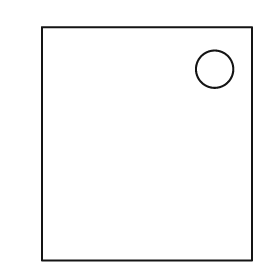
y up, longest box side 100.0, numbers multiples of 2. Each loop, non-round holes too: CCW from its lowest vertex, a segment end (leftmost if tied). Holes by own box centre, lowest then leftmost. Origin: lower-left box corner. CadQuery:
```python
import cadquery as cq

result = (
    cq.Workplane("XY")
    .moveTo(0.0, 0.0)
    .lineTo(90.0, 0.0)
    .lineTo(90.0, 100.0)
    .lineTo(0.0, 100.0)
    .close()
    .moveTo(74.0, 82.0)
    .circle(8.0)
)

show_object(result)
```